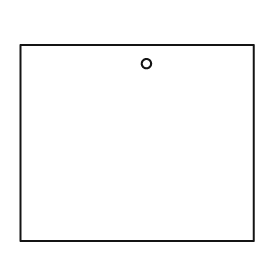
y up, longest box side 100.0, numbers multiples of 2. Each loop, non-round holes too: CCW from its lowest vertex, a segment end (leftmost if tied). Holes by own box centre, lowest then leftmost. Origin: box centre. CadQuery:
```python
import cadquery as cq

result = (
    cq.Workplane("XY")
    .moveTo(-50.0, -42.0)
    .lineTo(50.0, -42.0)
    .lineTo(50.0, 42.0)
    .lineTo(-50.0, 42.0)
    .close()
    .moveTo(4.0, 34.0)
    .circle(2.0)
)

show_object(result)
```